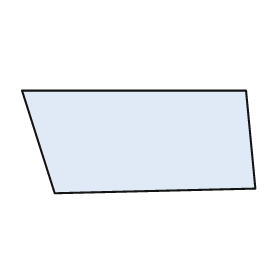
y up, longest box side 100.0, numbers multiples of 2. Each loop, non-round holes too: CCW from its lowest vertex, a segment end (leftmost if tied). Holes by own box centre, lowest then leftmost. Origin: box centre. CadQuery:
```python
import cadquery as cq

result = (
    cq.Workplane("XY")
    .moveTo(-36.0, -22.0)
    .lineTo(50.0, -20.0)
    .lineTo(46.0, 22.0)
    .lineTo(-50.0, 22.0)
    .close()
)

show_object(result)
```